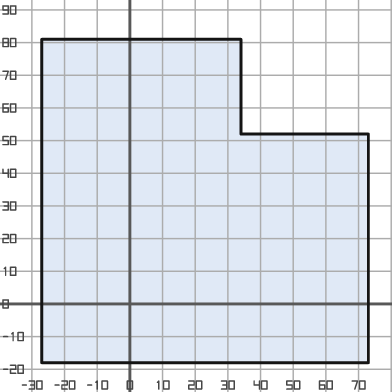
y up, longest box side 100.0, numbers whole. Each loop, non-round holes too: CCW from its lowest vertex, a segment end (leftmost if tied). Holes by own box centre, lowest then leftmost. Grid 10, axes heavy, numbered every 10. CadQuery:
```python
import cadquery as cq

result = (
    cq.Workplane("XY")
    .moveTo(-27.0, -18.0)
    .lineTo(73.0, -18.0)
    .lineTo(73.0, 52.0)
    .lineTo(34.0, 52.0)
    .lineTo(34.0, 81.0)
    .lineTo(-27.0, 81.0)
    .close()
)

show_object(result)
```